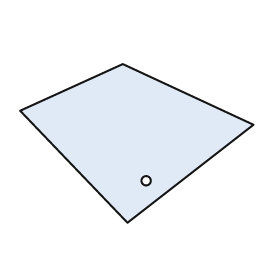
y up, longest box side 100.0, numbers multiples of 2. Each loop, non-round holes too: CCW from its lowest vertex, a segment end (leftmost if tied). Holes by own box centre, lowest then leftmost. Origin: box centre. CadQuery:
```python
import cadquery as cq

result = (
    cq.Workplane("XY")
    .moveTo(-4.0, -34.0)
    .lineTo(50.0, 8.0)
    .lineTo(-6.0, 34.0)
    .lineTo(-50.0, 14.0)
    .close()
    .moveTo(4.0, -16.0)
    .circle(2.0)
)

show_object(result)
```